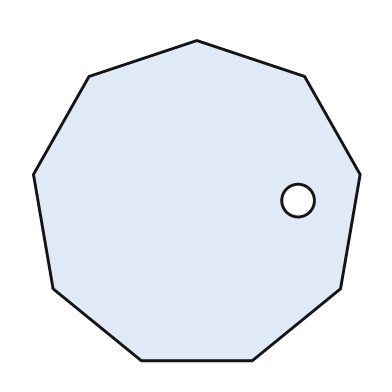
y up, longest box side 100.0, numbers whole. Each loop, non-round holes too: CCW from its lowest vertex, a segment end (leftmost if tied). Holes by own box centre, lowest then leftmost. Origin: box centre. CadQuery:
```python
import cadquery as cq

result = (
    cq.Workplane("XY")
    .moveTo(-17.0, -49.0)
    .lineTo(17.0, -49.0)
    .lineTo(44.0, -27.0)
    .lineTo(50.0, 8.0)
    .lineTo(33.0, 38.0)
    .lineTo(0.0, 49.0)
    .lineTo(-33.0, 38.0)
    .lineTo(-50.0, 8.0)
    .lineTo(-44.0, -27.0)
    .close()
    .moveTo(31.0, 0.0)
    .circle(5.0)
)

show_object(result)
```